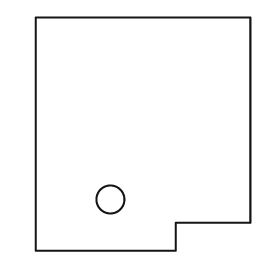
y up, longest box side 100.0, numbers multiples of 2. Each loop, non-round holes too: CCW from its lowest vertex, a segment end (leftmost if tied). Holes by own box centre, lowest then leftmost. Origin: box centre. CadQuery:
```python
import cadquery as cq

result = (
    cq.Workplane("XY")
    .moveTo(-46.0, -50.0)
    .lineTo(14.0, -50.0)
    .lineTo(14.0, -38.0)
    .lineTo(46.0, -38.0)
    .lineTo(46.0, 50.0)
    .lineTo(-46.0, 50.0)
    .close()
    .moveTo(-14.0, -28.0)
    .circle(6.0)
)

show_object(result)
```